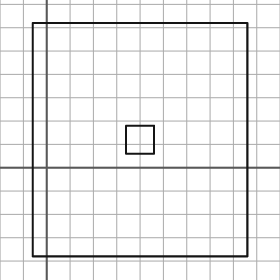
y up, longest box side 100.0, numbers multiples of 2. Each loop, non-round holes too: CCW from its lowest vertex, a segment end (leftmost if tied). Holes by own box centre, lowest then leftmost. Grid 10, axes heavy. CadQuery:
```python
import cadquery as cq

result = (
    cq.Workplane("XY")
    .moveTo(-6.0, -38.0)
    .lineTo(86.0, -38.0)
    .lineTo(86.0, 62.0)
    .lineTo(-6.0, 62.0)
    .close()
    .moveTo(34.0, 6.0)
    .lineTo(46.0, 6.0)
    .lineTo(46.0, 18.0)
    .lineTo(34.0, 18.0)
    .close()
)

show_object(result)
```